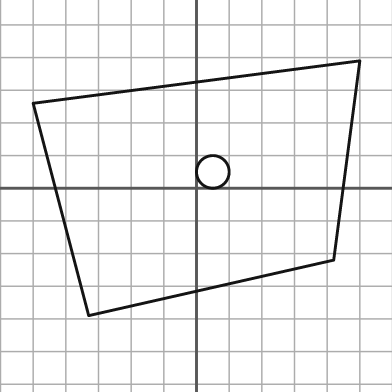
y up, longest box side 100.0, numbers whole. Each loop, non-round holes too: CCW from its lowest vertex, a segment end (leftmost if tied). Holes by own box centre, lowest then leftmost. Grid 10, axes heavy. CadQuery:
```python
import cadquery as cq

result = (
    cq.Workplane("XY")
    .moveTo(-33.0, -39.0)
    .lineTo(42.0, -22.0)
    .lineTo(50.0, 39.0)
    .lineTo(-50.0, 26.0)
    .close()
    .moveTo(5.0, 5.0)
    .circle(5.0)
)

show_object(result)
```